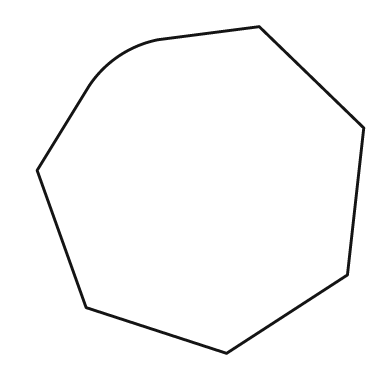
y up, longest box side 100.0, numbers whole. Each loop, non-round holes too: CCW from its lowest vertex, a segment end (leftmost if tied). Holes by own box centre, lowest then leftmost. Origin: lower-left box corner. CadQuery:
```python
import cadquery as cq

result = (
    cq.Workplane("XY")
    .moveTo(58.0, 0.0)
    .lineTo(95.0, 24.0)
    .lineTo(100.0, 69.0)
    .lineTo(68.0, 100.0)
    .lineTo(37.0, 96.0)
    .threePointArc((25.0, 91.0), (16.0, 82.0))
    .lineTo(0.0, 56.0)
    .lineTo(15.0, 14.0)
    .close()
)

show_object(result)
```